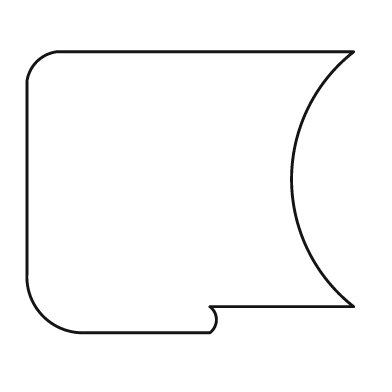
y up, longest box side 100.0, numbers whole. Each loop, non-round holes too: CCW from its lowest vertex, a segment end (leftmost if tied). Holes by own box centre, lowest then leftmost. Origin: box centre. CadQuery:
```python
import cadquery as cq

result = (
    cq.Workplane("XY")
    .moveTo(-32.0, -43.0)
    .lineTo(6.0, -43.0)
    .threePointArc((8.0, -39.0), (6.0, -35.0))
    .lineTo(50.0, -35.0)
    .threePointArc((31.0, 4.0), (50.0, 43.0))
    .lineTo(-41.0, 43.0)
    .threePointArc((-47.0, 40.0), (-50.0, 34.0))
    .lineTo(-50.0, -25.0)
    .threePointArc((-45.0, -38.0), (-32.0, -43.0))
    .close()
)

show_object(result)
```